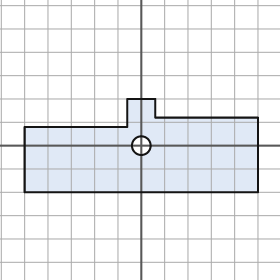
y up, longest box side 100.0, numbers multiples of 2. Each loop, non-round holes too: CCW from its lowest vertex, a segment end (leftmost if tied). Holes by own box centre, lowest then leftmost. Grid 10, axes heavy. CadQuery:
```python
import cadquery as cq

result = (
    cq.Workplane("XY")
    .moveTo(-50.0, -20.0)
    .lineTo(50.0, -20.0)
    .lineTo(50.0, 12.0)
    .lineTo(6.0, 12.0)
    .lineTo(6.0, 20.0)
    .lineTo(-6.0, 20.0)
    .lineTo(-6.0, 8.0)
    .lineTo(-50.0, 8.0)
    .close()
    .moveTo(0.0, 0.0)
    .circle(4.0)
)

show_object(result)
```